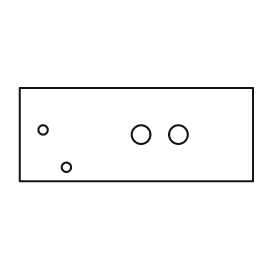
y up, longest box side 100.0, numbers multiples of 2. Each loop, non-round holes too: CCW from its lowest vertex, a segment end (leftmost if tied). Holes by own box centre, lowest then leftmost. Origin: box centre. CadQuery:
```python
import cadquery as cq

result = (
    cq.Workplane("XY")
    .moveTo(-50.0, -20.0)
    .lineTo(50.0, -20.0)
    .lineTo(50.0, 20.0)
    .lineTo(-50.0, 20.0)
    .close()
    .moveTo(-30.0, -14.0)
    .circle(2.0)
    .moveTo(2.0, 0.0)
    .circle(4.0)
    .moveTo(18.0, 0.0)
    .circle(4.0)
    .moveTo(-40.0, 2.0)
    .circle(2.0)
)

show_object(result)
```